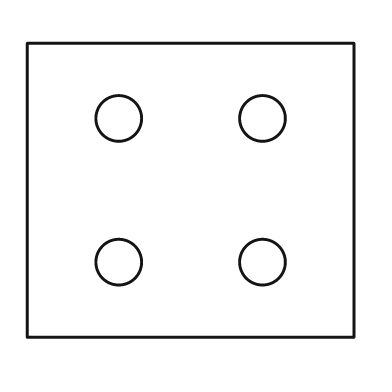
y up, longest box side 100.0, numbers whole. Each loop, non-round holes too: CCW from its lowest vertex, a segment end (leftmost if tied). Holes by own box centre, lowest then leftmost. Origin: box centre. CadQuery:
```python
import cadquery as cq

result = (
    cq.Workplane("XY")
    .moveTo(-50.0, -45.0)
    .lineTo(50.0, -45.0)
    .lineTo(50.0, 45.0)
    .lineTo(-50.0, 45.0)
    .close()
    .moveTo(-22.0, -22.0)
    .circle(7.0)
    .moveTo(22.0, -22.0)
    .circle(7.0)
    .moveTo(-22.0, 22.0)
    .circle(7.0)
    .moveTo(22.0, 22.0)
    .circle(7.0)
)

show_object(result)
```